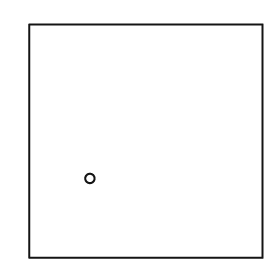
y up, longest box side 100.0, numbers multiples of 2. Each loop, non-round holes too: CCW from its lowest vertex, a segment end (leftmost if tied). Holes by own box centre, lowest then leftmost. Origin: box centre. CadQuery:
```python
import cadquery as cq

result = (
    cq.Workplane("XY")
    .moveTo(-50.0, -50.0)
    .lineTo(50.0, -50.0)
    .lineTo(50.0, 50.0)
    .lineTo(-50.0, 50.0)
    .close()
    .moveTo(-24.0, -16.0)
    .circle(2.0)
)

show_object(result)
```